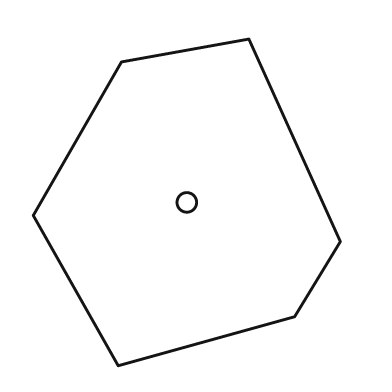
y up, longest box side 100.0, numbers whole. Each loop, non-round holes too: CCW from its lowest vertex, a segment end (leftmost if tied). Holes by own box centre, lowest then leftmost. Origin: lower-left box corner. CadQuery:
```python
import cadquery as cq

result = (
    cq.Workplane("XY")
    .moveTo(26.0, 0.0)
    .lineTo(80.0, 15.0)
    .lineTo(94.0, 38.0)
    .lineTo(66.0, 100.0)
    .lineTo(27.0, 93.0)
    .lineTo(0.0, 46.0)
    .close()
    .moveTo(47.0, 50.0)
    .circle(3.0)
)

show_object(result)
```